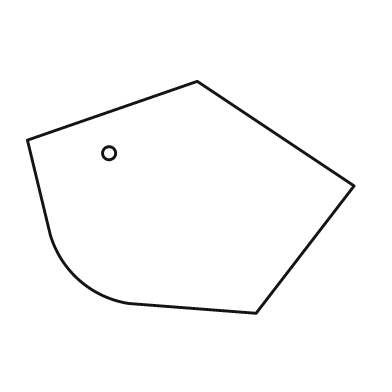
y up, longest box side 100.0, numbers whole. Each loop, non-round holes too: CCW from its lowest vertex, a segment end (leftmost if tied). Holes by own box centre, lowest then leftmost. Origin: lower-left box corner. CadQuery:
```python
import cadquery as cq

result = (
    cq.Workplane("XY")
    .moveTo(70.0, 0.0)
    .lineTo(100.0, 39.0)
    .lineTo(52.0, 71.0)
    .lineTo(0.0, 53.0)
    .lineTo(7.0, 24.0)
    .threePointArc((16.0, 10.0), (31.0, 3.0))
    .close()
    .moveTo(25.0, 49.0)
    .circle(2.0)
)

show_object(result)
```